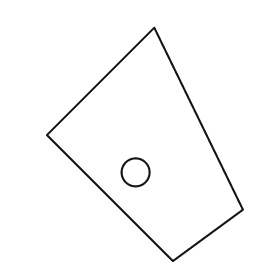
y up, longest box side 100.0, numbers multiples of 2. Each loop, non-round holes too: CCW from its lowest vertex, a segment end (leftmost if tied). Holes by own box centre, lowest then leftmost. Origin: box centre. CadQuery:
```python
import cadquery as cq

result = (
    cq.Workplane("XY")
    .moveTo(12.0, -50.0)
    .lineTo(42.0, -28.0)
    .lineTo(4.0, 50.0)
    .lineTo(-42.0, 4.0)
    .close()
    .moveTo(-4.0, -12.0)
    .circle(6.0)
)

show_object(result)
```